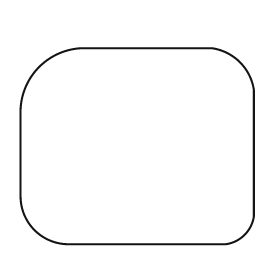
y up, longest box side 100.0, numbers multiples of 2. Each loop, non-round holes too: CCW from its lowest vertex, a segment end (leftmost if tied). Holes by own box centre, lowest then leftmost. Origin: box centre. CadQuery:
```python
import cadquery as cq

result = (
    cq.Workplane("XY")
    .moveTo(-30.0, -42.0)
    .lineTo(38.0, -42.0)
    .threePointArc((46.0, -38.0), (50.0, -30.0))
    .lineTo(50.0, 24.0)
    .threePointArc((44.0, 36.0), (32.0, 42.0))
    .lineTo(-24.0, 42.0)
    .threePointArc((-42.0, 34.0), (-50.0, 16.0))
    .lineTo(-50.0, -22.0)
    .threePointArc((-44.0, -36.0), (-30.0, -42.0))
    .close()
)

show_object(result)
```